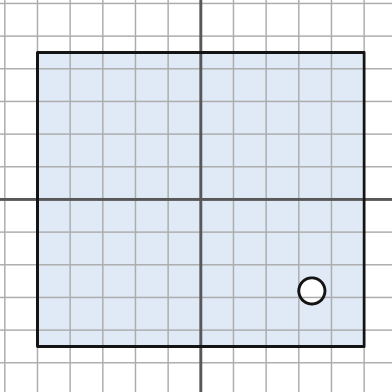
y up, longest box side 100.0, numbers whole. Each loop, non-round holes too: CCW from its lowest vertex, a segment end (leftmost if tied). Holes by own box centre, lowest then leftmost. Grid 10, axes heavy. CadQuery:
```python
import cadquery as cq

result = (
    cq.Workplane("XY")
    .moveTo(-50.0, -45.0)
    .lineTo(50.0, -45.0)
    .lineTo(50.0, 45.0)
    .lineTo(-50.0, 45.0)
    .close()
    .moveTo(34.0, -28.0)
    .circle(4.0)
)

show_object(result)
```